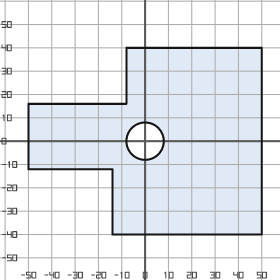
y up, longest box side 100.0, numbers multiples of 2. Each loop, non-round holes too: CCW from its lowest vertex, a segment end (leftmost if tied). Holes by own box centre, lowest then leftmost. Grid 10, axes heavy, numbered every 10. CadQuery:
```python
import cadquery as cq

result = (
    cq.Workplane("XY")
    .moveTo(-14.0, -40.0)
    .lineTo(50.0, -40.0)
    .lineTo(50.0, 40.0)
    .lineTo(-8.0, 40.0)
    .lineTo(-8.0, 16.0)
    .lineTo(-50.0, 16.0)
    .lineTo(-50.0, -12.0)
    .lineTo(-14.0, -12.0)
    .close()
    .moveTo(0.0, 0.0)
    .circle(8.0)
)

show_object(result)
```